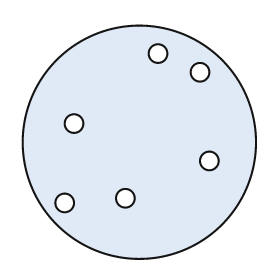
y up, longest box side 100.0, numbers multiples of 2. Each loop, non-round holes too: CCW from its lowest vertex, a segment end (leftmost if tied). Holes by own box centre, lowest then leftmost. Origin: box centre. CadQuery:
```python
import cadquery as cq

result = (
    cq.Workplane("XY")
    .moveTo(0.0, 0.0)
    .circle(50.0)
    .moveTo(-32.0, -26.0)
    .circle(4.0)
    .moveTo(-6.0, -24.0)
    .circle(4.0)
    .moveTo(30.0, -8.0)
    .circle(4.0)
    .moveTo(-28.0, 8.0)
    .circle(4.0)
    .moveTo(26.0, 30.0)
    .circle(4.0)
    .moveTo(8.0, 38.0)
    .circle(4.0)
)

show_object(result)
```